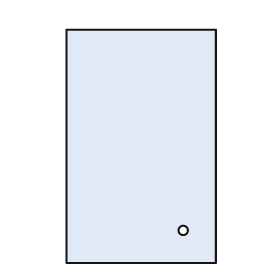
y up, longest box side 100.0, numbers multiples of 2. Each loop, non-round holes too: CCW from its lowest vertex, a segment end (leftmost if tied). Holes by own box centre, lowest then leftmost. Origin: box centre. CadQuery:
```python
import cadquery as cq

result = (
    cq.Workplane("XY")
    .moveTo(-32.0, -50.0)
    .lineTo(32.0, -50.0)
    .lineTo(32.0, 50.0)
    .lineTo(-32.0, 50.0)
    .close()
    .moveTo(18.0, -36.0)
    .circle(2.0)
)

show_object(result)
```